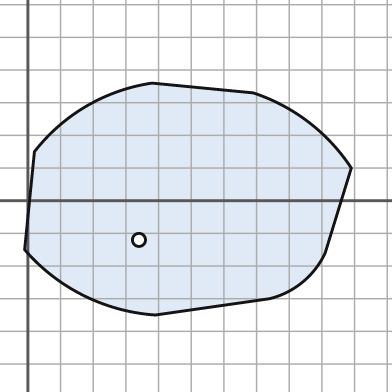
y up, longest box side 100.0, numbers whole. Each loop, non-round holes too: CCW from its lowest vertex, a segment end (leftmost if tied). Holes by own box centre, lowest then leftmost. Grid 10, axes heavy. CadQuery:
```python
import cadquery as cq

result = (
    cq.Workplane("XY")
    .moveTo(39.0, -35.0)
    .lineTo(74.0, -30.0)
    .threePointArc((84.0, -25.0), (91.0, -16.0))
    .lineTo(99.0, 10.0)
    .threePointArc((86.0, 24.0), (69.0, 33.0))
    .lineTo(38.0, 36.0)
    .threePointArc((18.0, 29.0), (2.0, 15.0))
    .lineTo(-1.0, -15.0)
    .threePointArc((17.0, -29.0), (39.0, -35.0))
    .close()
    .moveTo(34.0, -12.0)
    .circle(2.0)
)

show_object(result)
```